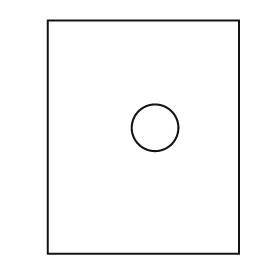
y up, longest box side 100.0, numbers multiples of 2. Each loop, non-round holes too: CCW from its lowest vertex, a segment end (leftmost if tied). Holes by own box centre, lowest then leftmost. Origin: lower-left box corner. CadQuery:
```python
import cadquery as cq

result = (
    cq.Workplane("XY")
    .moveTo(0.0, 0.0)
    .lineTo(82.0, 0.0)
    .lineTo(82.0, 100.0)
    .lineTo(0.0, 100.0)
    .close()
    .moveTo(46.0, 54.0)
    .circle(10.0)
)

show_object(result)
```